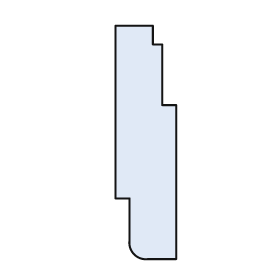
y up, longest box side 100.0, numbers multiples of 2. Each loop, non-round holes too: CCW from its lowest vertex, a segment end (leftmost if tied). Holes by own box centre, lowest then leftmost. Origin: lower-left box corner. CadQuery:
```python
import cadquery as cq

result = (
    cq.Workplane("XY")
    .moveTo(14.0, 0.0)
    .lineTo(26.0, 0.0)
    .lineTo(26.0, 66.0)
    .lineTo(20.0, 66.0)
    .lineTo(20.0, 92.0)
    .lineTo(16.0, 92.0)
    .lineTo(16.0, 100.0)
    .lineTo(0.0, 100.0)
    .lineTo(0.0, 26.0)
    .lineTo(6.0, 26.0)
    .lineTo(6.0, 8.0)
    .threePointArc((8.0, 2.0), (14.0, 0.0))
    .close()
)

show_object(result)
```